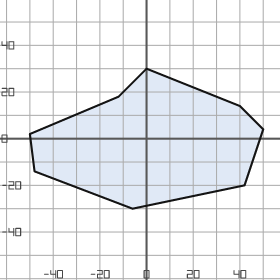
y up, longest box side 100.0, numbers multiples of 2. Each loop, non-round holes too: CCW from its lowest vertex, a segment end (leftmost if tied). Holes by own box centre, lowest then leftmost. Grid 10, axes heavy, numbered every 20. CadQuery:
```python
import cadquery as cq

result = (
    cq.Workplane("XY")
    .moveTo(-6.0, -30.0)
    .lineTo(42.0, -20.0)
    .lineTo(50.0, 4.0)
    .lineTo(40.0, 14.0)
    .lineTo(0.0, 30.0)
    .lineTo(-12.0, 18.0)
    .lineTo(-50.0, 2.0)
    .lineTo(-48.0, -14.0)
    .close()
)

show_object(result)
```